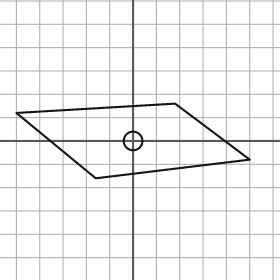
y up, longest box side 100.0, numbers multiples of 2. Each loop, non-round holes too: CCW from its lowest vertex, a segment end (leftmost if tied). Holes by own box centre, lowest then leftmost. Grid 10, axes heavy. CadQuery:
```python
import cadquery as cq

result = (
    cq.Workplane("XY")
    .moveTo(-16.0, -16.0)
    .lineTo(50.0, -8.0)
    .lineTo(18.0, 16.0)
    .lineTo(-50.0, 12.0)
    .close()
    .moveTo(0.0, 0.0)
    .circle(4.0)
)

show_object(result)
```